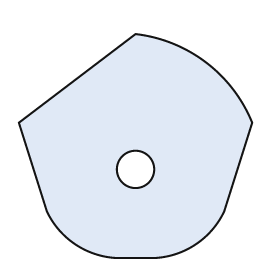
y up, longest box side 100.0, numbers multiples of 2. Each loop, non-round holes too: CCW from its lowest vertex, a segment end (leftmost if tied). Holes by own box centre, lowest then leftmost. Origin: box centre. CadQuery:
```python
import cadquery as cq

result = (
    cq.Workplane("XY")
    .moveTo(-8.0, -48.0)
    .lineTo(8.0, -48.0)
    .threePointArc((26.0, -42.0), (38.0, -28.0))
    .lineTo(50.0, 10.0)
    .threePointArc((30.0, 36.0), (0.0, 48.0))
    .lineTo(-50.0, 10.0)
    .lineTo(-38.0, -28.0)
    .threePointArc((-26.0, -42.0), (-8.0, -48.0))
    .close()
    .moveTo(0.0, -10.0)
    .circle(8.0)
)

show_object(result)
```